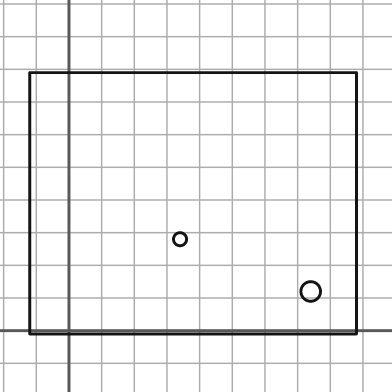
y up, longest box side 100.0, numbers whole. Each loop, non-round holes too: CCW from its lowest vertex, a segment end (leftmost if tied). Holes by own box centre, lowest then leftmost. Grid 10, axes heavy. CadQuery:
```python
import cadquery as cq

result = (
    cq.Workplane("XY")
    .moveTo(-12.0, -1.0)
    .lineTo(88.0, -1.0)
    .lineTo(88.0, 79.0)
    .lineTo(-12.0, 79.0)
    .close()
    .moveTo(74.0, 12.0)
    .circle(3.0)
    .moveTo(34.0, 28.0)
    .circle(2.0)
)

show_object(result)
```